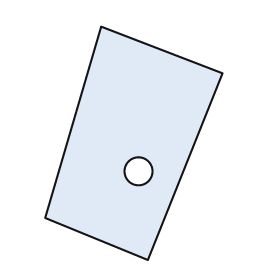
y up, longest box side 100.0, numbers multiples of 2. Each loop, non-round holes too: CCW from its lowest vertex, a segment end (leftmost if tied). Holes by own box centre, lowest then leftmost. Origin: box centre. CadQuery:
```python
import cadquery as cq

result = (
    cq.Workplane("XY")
    .moveTo(6.0, -50.0)
    .lineTo(38.0, 30.0)
    .lineTo(-14.0, 50.0)
    .lineTo(-38.0, -32.0)
    .close()
    .moveTo(2.0, -12.0)
    .circle(6.0)
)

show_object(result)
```